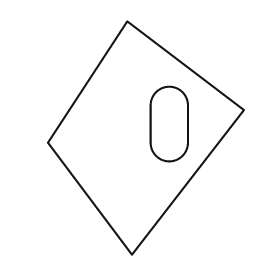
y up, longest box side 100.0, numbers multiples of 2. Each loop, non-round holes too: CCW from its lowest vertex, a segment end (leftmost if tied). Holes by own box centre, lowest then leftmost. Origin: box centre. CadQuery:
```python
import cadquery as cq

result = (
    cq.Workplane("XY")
    .moveTo(-6.0, -50.0)
    .lineTo(42.0, 12.0)
    .lineTo(-8.0, 50.0)
    .lineTo(-42.0, -2.0)
    .close()
    .moveTo(2.0, -2.0)
    .threePointArc((10.0, -10.0), (18.0, -2.0))
    .lineTo(18.0, 14.0)
    .threePointArc((10.0, 22.0), (2.0, 14.0))
    .close()
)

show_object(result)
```